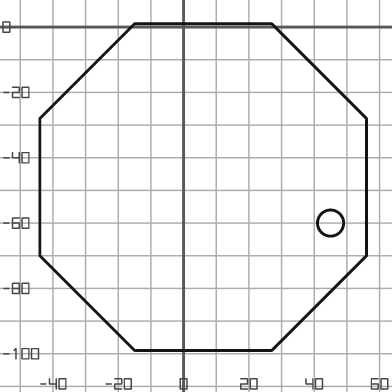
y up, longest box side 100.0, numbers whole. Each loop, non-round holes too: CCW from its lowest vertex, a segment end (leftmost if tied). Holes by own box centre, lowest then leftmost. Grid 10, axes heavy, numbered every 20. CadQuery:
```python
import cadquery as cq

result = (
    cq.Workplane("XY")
    .moveTo(-15.0, -99.0)
    .lineTo(27.0, -99.0)
    .lineTo(56.0, -70.0)
    .lineTo(56.0, -28.0)
    .lineTo(27.0, 1.0)
    .lineTo(-15.0, 1.0)
    .lineTo(-44.0, -28.0)
    .lineTo(-44.0, -70.0)
    .close()
    .moveTo(45.0, -60.0)
    .circle(4.0)
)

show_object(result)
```